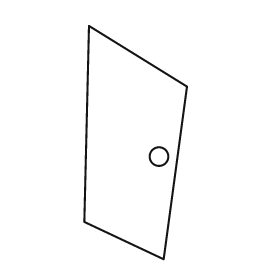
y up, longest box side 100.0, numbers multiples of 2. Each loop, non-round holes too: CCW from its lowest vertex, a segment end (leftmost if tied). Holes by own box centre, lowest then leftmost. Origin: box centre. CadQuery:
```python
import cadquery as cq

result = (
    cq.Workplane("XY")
    .moveTo(12.0, -50.0)
    .lineTo(22.0, 24.0)
    .lineTo(-20.0, 50.0)
    .lineTo(-22.0, -34.0)
    .close()
    .moveTo(10.0, -6.0)
    .circle(4.0)
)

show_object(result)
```